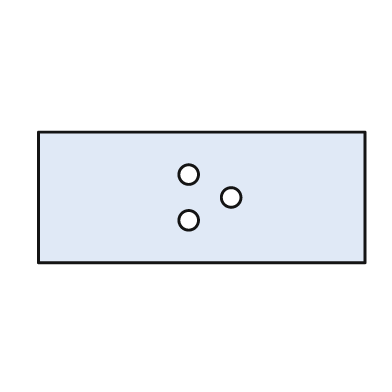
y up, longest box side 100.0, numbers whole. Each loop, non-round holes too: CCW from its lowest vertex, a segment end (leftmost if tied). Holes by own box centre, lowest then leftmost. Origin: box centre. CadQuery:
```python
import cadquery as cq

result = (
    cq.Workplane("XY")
    .moveTo(-50.0, -20.0)
    .lineTo(50.0, -20.0)
    .lineTo(50.0, 20.0)
    .lineTo(-50.0, 20.0)
    .close()
    .moveTo(-4.0, -7.0)
    .circle(3.0)
    .moveTo(9.0, 0.0)
    .circle(3.0)
    .moveTo(-4.0, 7.0)
    .circle(3.0)
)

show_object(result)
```